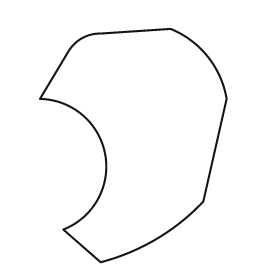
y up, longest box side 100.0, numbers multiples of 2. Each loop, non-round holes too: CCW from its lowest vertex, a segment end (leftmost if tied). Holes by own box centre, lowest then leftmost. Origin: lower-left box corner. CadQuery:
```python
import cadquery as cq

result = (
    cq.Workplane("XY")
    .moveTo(26.0, 0.0)
    .threePointArc((50.0, 10.0), (70.0, 26.0))
    .lineTo(80.0, 70.0)
    .threePointArc((72.0, 88.0), (56.0, 100.0))
    .lineTo(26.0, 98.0)
    .threePointArc((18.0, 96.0), (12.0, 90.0))
    .lineTo(0.0, 70.0)
    .threePointArc((28.0, 46.0), (10.0, 14.0))
    .close()
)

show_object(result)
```